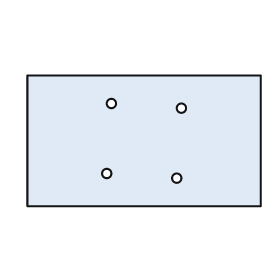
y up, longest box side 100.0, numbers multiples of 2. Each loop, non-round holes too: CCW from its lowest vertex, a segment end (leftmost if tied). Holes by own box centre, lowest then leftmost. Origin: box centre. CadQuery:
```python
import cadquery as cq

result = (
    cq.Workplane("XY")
    .moveTo(-50.0, -28.0)
    .lineTo(50.0, -28.0)
    .lineTo(50.0, 28.0)
    .lineTo(-50.0, 28.0)
    .close()
    .moveTo(14.0, -16.0)
    .circle(2.0)
    .moveTo(-16.0, -14.0)
    .circle(2.0)
    .moveTo(16.0, 14.0)
    .circle(2.0)
    .moveTo(-14.0, 16.0)
    .circle(2.0)
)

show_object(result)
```